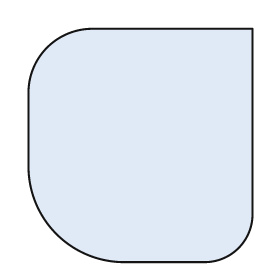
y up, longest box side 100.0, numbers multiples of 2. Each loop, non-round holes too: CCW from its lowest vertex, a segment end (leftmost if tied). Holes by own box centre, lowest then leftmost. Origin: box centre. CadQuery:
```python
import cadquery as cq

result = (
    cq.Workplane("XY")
    .moveTo(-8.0, -50.0)
    .lineTo(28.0, -50.0)
    .threePointArc((42.0, -44.0), (48.0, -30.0))
    .lineTo(48.0, 50.0)
    .lineTo(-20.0, 50.0)
    .threePointArc((-40.0, 42.0), (-48.0, 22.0))
    .lineTo(-48.0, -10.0)
    .threePointArc((-36.0, -38.0), (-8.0, -50.0))
    .close()
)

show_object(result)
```